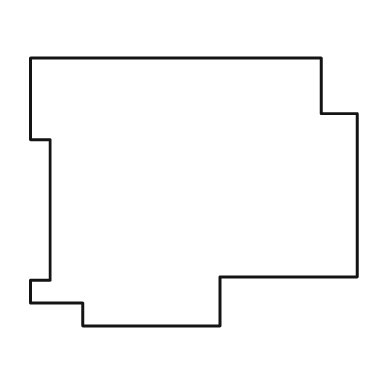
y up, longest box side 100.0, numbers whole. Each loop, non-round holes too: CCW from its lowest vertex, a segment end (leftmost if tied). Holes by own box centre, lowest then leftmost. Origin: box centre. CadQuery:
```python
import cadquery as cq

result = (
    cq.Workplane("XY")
    .moveTo(-34.0, -41.0)
    .lineTo(8.0, -41.0)
    .lineTo(8.0, -26.0)
    .lineTo(50.0, -26.0)
    .lineTo(50.0, 24.0)
    .lineTo(39.0, 24.0)
    .lineTo(39.0, 41.0)
    .lineTo(-50.0, 41.0)
    .lineTo(-50.0, 16.0)
    .lineTo(-44.0, 16.0)
    .lineTo(-44.0, -27.0)
    .lineTo(-50.0, -27.0)
    .lineTo(-50.0, -34.0)
    .lineTo(-34.0, -34.0)
    .close()
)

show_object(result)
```